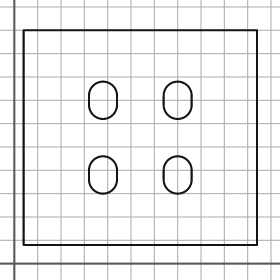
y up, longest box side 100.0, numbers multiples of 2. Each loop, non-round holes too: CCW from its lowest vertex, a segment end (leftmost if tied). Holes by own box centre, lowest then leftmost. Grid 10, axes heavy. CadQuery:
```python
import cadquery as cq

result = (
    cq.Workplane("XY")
    .moveTo(4.0, 8.0)
    .lineTo(104.0, 8.0)
    .lineTo(104.0, 100.0)
    .lineTo(4.0, 100.0)
    .close()
    .moveTo(32.0, 36.0)
    .threePointArc((38.0, 30.0), (44.0, 36.0))
    .lineTo(44.0, 40.0)
    .threePointArc((38.0, 46.0), (32.0, 40.0))
    .close()
    .moveTo(64.0, 36.0)
    .threePointArc((70.0, 30.0), (76.0, 36.0))
    .lineTo(76.0, 40.0)
    .threePointArc((70.0, 46.0), (64.0, 40.0))
    .close()
    .moveTo(32.0, 68.0)
    .threePointArc((38.0, 62.0), (44.0, 68.0))
    .lineTo(44.0, 72.0)
    .threePointArc((38.0, 78.0), (32.0, 72.0))
    .close()
    .moveTo(64.0, 68.0)
    .threePointArc((70.0, 62.0), (76.0, 68.0))
    .lineTo(76.0, 72.0)
    .threePointArc((70.0, 78.0), (64.0, 72.0))
    .close()
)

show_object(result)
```